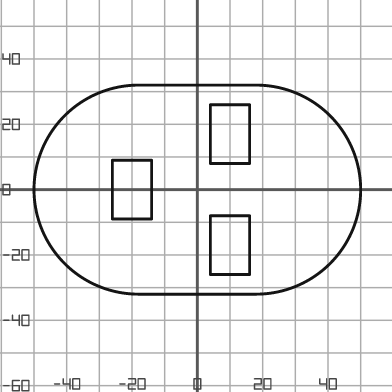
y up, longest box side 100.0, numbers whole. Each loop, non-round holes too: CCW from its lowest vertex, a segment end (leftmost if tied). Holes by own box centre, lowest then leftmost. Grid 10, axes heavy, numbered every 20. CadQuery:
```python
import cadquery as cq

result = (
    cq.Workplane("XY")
    .moveTo(-18.0, -32.0)
    .lineTo(18.0, -32.0)
    .threePointArc((50.0, 0.0), (18.0, 32.0))
    .lineTo(-18.0, 32.0)
    .threePointArc((-50.0, 0.0), (-18.0, -32.0))
    .close()
    .moveTo(4.0, -26.0)
    .lineTo(16.0, -26.0)
    .lineTo(16.0, -8.0)
    .lineTo(4.0, -8.0)
    .close()
    .moveTo(-26.0, -9.0)
    .lineTo(-14.0, -9.0)
    .lineTo(-14.0, 9.0)
    .lineTo(-26.0, 9.0)
    .close()
    .moveTo(4.0, 8.0)
    .lineTo(16.0, 8.0)
    .lineTo(16.0, 26.0)
    .lineTo(4.0, 26.0)
    .close()
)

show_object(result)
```